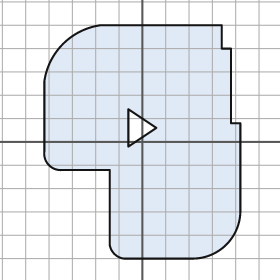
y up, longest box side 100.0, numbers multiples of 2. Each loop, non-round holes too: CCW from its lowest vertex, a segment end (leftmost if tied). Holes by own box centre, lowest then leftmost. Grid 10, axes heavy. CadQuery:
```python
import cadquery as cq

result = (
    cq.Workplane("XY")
    .moveTo(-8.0, -50.0)
    .lineTo(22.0, -50.0)
    .threePointArc((36.0, -44.0), (42.0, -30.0))
    .lineTo(42.0, 8.0)
    .lineTo(38.0, 8.0)
    .lineTo(38.0, 40.0)
    .lineTo(34.0, 40.0)
    .lineTo(34.0, 50.0)
    .lineTo(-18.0, 50.0)
    .threePointArc((-34.0, 42.0), (-42.0, 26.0))
    .lineTo(-42.0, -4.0)
    .threePointArc((-40.0, -10.0), (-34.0, -12.0))
    .lineTo(-14.0, -12.0)
    .lineTo(-14.0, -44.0)
    .threePointArc((-12.0, -48.0), (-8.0, -50.0))
    .close()
    .moveTo(-6.0, -2.0)
    .lineTo(6.0, 6.0)
    .lineTo(-6.0, 14.0)
    .close()
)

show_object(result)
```